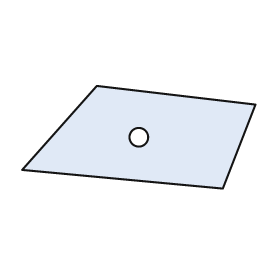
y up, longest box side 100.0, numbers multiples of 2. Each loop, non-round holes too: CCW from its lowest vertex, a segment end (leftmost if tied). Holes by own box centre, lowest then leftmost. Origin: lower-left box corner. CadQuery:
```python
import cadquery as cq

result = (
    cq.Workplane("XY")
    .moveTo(86.0, 0.0)
    .lineTo(100.0, 36.0)
    .lineTo(32.0, 44.0)
    .lineTo(0.0, 8.0)
    .close()
    .moveTo(50.0, 22.0)
    .circle(4.0)
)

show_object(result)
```